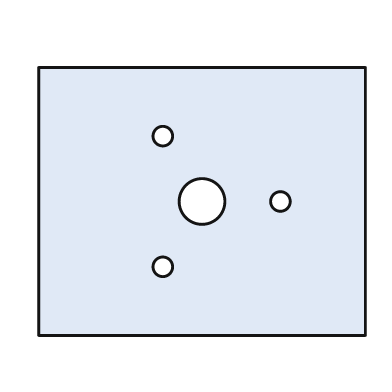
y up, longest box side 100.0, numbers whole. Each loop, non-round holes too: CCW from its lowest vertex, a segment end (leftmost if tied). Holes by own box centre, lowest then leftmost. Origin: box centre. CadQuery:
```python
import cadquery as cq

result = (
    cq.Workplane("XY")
    .moveTo(-50.0, -41.0)
    .lineTo(50.0, -41.0)
    .lineTo(50.0, 41.0)
    .lineTo(-50.0, 41.0)
    .close()
    .moveTo(-12.0, -20.0)
    .circle(3.0)
    .moveTo(0.0, 0.0)
    .circle(7.0)
    .moveTo(24.0, 0.0)
    .circle(3.0)
    .moveTo(-12.0, 20.0)
    .circle(3.0)
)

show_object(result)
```